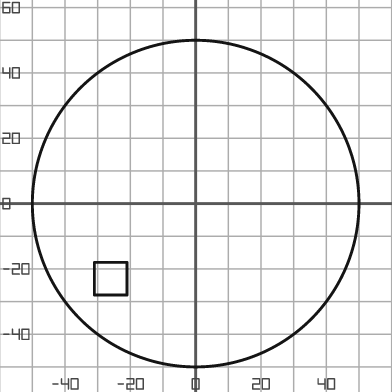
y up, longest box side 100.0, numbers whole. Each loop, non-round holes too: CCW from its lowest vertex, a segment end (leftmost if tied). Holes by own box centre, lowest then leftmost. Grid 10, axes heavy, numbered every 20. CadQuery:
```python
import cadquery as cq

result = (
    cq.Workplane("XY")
    .moveTo(0.0, 0.0)
    .circle(50.0)
    .moveTo(-31.0, -28.0)
    .lineTo(-21.0, -28.0)
    .lineTo(-21.0, -18.0)
    .lineTo(-31.0, -18.0)
    .close()
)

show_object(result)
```